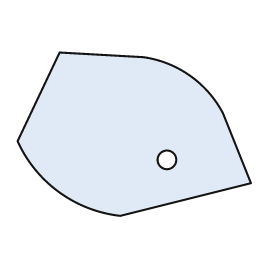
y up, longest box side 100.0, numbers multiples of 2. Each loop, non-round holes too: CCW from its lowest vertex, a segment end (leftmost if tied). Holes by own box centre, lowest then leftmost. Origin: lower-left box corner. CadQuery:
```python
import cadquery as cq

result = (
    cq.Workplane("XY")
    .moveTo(44.0, 0.0)
    .lineTo(100.0, 14.0)
    .lineTo(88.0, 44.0)
    .threePointArc((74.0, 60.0), (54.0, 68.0))
    .lineTo(18.0, 70.0)
    .lineTo(0.0, 32.0)
    .threePointArc((18.0, 10.0), (44.0, 0.0))
    .close()
    .moveTo(64.0, 24.0)
    .circle(4.0)
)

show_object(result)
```